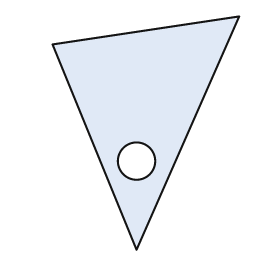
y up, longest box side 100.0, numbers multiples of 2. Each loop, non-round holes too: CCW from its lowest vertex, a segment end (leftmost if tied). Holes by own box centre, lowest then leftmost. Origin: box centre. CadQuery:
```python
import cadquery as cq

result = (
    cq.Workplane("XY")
    .moveTo(-4.0, -50.0)
    .lineTo(40.0, 50.0)
    .lineTo(-40.0, 38.0)
    .close()
    .moveTo(-4.0, -12.0)
    .circle(8.0)
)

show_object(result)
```